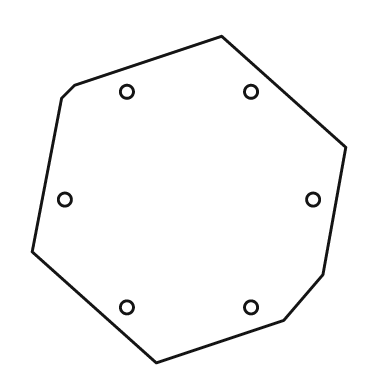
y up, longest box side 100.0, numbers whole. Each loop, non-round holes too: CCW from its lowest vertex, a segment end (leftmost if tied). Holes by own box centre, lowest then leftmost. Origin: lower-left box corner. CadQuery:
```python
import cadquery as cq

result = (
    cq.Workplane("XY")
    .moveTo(38.0, 0.0)
    .lineTo(77.0, 13.0)
    .lineTo(89.0, 27.0)
    .lineTo(96.0, 66.0)
    .lineTo(58.0, 100.0)
    .lineTo(13.0, 85.0)
    .lineTo(9.0, 81.0)
    .lineTo(0.0, 34.0)
    .close()
    .moveTo(29.0, 17.0)
    .circle(2.0)
    .moveTo(67.0, 17.0)
    .circle(2.0)
    .moveTo(10.0, 50.0)
    .circle(2.0)
    .moveTo(86.0, 50.0)
    .circle(2.0)
    .moveTo(29.0, 83.0)
    .circle(2.0)
    .moveTo(67.0, 83.0)
    .circle(2.0)
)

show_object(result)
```